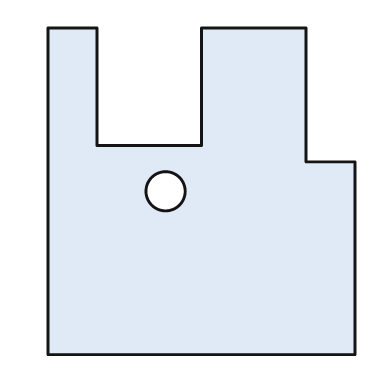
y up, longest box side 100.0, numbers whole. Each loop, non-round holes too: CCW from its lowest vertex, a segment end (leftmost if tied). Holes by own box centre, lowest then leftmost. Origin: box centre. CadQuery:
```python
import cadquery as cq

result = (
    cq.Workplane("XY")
    .moveTo(-47.0, -50.0)
    .lineTo(47.0, -50.0)
    .lineTo(47.0, 9.0)
    .lineTo(32.0, 9.0)
    .lineTo(32.0, 50.0)
    .lineTo(0.0, 50.0)
    .lineTo(0.0, 14.0)
    .lineTo(-32.0, 14.0)
    .lineTo(-32.0, 50.0)
    .lineTo(-47.0, 50.0)
    .close()
    .moveTo(-11.0, 0.0)
    .circle(6.0)
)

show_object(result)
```